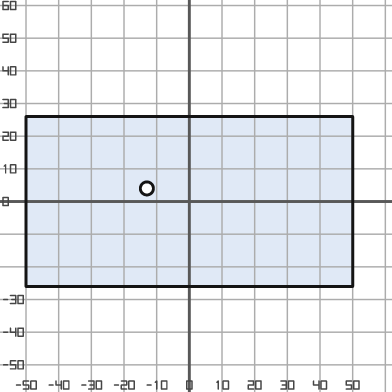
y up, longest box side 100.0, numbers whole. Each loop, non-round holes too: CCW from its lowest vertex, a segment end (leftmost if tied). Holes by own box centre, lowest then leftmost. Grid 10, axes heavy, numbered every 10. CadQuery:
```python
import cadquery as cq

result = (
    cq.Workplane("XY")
    .moveTo(-50.0, -26.0)
    .lineTo(50.0, -26.0)
    .lineTo(50.0, 26.0)
    .lineTo(-50.0, 26.0)
    .close()
    .moveTo(-13.0, 4.0)
    .circle(2.0)
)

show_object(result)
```